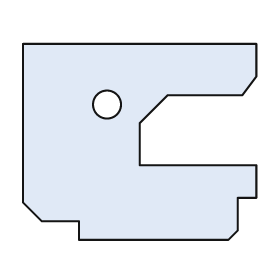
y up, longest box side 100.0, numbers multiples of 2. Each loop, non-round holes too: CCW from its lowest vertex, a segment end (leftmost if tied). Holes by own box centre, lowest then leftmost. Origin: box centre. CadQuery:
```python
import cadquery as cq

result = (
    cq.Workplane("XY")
    .moveTo(-26.0, -42.0)
    .lineTo(38.0, -42.0)
    .lineTo(42.0, -38.0)
    .lineTo(42.0, -24.0)
    .lineTo(50.0, -24.0)
    .lineTo(50.0, -10.0)
    .lineTo(0.0, -10.0)
    .lineTo(0.0, 8.0)
    .lineTo(12.0, 20.0)
    .lineTo(44.0, 20.0)
    .lineTo(50.0, 28.0)
    .lineTo(50.0, 42.0)
    .lineTo(-50.0, 42.0)
    .lineTo(-50.0, -26.0)
    .lineTo(-42.0, -34.0)
    .lineTo(-26.0, -34.0)
    .close()
    .moveTo(-14.0, 16.0)
    .circle(6.0)
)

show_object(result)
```